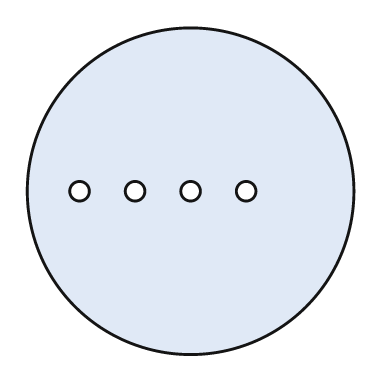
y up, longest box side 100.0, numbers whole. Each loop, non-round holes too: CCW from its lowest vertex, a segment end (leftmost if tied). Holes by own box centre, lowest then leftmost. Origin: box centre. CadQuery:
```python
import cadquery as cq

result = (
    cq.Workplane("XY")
    .moveTo(0.0, 0.0)
    .circle(50.0)
    .moveTo(-34.0, 0.0)
    .circle(3.0)
    .moveTo(-17.0, 0.0)
    .circle(3.0)
    .moveTo(0.0, 0.0)
    .circle(3.0)
    .moveTo(17.0, 0.0)
    .circle(3.0)
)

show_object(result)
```